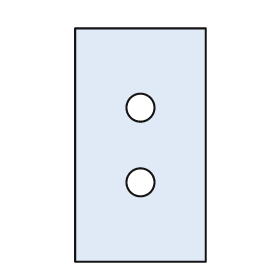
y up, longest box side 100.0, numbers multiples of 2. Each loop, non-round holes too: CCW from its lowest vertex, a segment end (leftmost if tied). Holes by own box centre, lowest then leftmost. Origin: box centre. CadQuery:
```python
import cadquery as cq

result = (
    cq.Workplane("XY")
    .moveTo(-28.0, -50.0)
    .lineTo(28.0, -50.0)
    .lineTo(28.0, 50.0)
    .lineTo(-28.0, 50.0)
    .close()
    .moveTo(0.0, -16.0)
    .circle(6.0)
    .moveTo(0.0, 16.0)
    .circle(6.0)
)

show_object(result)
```